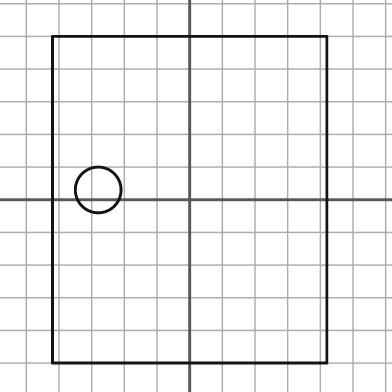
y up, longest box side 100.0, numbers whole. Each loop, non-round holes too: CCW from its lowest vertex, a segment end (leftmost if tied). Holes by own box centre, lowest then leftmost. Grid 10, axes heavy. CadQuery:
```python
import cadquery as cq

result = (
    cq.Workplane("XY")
    .moveTo(-42.0, -50.0)
    .lineTo(42.0, -50.0)
    .lineTo(42.0, 50.0)
    .lineTo(-42.0, 50.0)
    .close()
    .moveTo(-28.0, 3.0)
    .circle(7.0)
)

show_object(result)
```